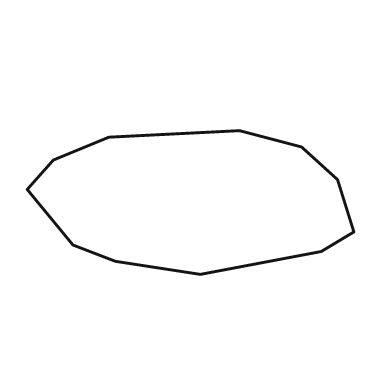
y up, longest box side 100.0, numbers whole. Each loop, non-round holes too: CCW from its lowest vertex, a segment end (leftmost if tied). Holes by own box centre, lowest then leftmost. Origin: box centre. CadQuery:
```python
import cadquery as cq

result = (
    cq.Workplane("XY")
    .moveTo(3.0, -22.0)
    .lineTo(40.0, -15.0)
    .lineTo(50.0, -9.0)
    .lineTo(45.0, 7.0)
    .lineTo(34.0, 17.0)
    .lineTo(15.0, 22.0)
    .lineTo(-25.0, 20.0)
    .lineTo(-42.0, 13.0)
    .lineTo(-50.0, 4.0)
    .lineTo(-36.0, -13.0)
    .lineTo(-23.0, -18.0)
    .close()
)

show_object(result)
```